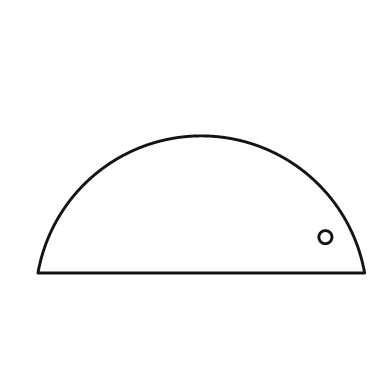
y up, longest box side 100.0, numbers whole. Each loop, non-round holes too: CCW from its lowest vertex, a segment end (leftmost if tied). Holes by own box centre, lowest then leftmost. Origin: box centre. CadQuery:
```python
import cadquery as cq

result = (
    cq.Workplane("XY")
    .moveTo(-50.0, -21.0)
    .lineTo(50.0, -21.0)
    .threePointArc((0.0, 21.0), (-50.0, -21.0))
    .close()
    .moveTo(38.0, -10.0)
    .circle(2.0)
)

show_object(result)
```